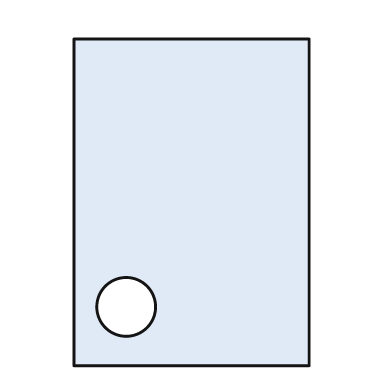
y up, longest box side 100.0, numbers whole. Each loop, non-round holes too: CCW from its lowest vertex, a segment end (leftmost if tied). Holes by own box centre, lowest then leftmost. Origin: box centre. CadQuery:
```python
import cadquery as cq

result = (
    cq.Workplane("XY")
    .moveTo(-36.0, -50.0)
    .lineTo(36.0, -50.0)
    .lineTo(36.0, 50.0)
    .lineTo(-36.0, 50.0)
    .close()
    .moveTo(-20.0, -32.0)
    .circle(9.0)
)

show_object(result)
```